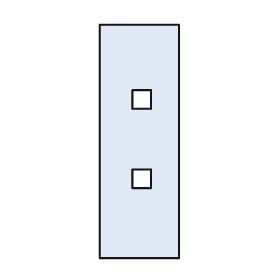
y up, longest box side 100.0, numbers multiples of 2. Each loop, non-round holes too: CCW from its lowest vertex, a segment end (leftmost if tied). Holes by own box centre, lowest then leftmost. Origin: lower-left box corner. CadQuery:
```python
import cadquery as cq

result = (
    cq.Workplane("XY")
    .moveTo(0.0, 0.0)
    .lineTo(34.0, 0.0)
    .lineTo(34.0, 100.0)
    .lineTo(0.0, 100.0)
    .close()
    .moveTo(14.0, 30.0)
    .lineTo(22.0, 30.0)
    .lineTo(22.0, 38.0)
    .lineTo(14.0, 38.0)
    .close()
    .moveTo(14.0, 64.0)
    .lineTo(22.0, 64.0)
    .lineTo(22.0, 72.0)
    .lineTo(14.0, 72.0)
    .close()
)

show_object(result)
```